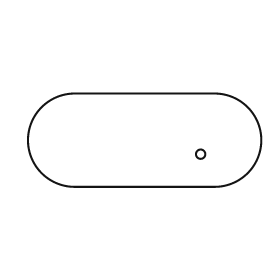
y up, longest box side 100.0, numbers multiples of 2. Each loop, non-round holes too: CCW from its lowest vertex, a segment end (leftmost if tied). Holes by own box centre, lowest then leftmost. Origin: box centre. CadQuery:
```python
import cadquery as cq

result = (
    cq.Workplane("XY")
    .moveTo(-30.0, -20.0)
    .lineTo(30.0, -20.0)
    .threePointArc((50.0, 0.0), (30.0, 20.0))
    .lineTo(-30.0, 20.0)
    .threePointArc((-50.0, 0.0), (-30.0, -20.0))
    .close()
    .moveTo(24.0, -6.0)
    .circle(2.0)
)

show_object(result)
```